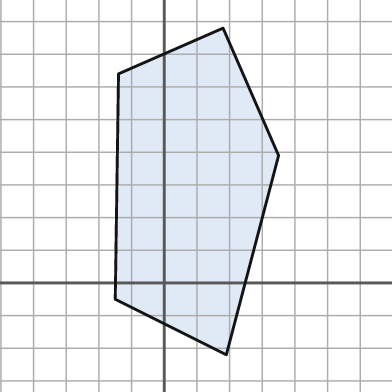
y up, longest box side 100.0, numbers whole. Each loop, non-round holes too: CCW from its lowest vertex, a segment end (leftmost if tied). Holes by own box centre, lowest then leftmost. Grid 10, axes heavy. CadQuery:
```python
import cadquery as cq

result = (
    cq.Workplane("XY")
    .moveTo(19.0, -22.0)
    .lineTo(35.0, 39.0)
    .lineTo(18.0, 78.0)
    .lineTo(-14.0, 64.0)
    .lineTo(-15.0, -5.0)
    .close()
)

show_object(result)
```